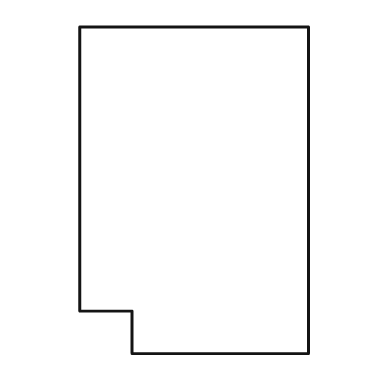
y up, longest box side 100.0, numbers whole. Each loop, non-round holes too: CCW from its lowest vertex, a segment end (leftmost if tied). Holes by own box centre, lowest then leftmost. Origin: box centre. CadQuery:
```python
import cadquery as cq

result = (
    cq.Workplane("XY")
    .moveTo(-19.0, -50.0)
    .lineTo(35.0, -50.0)
    .lineTo(35.0, 50.0)
    .lineTo(-35.0, 50.0)
    .lineTo(-35.0, -37.0)
    .lineTo(-19.0, -37.0)
    .close()
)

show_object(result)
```